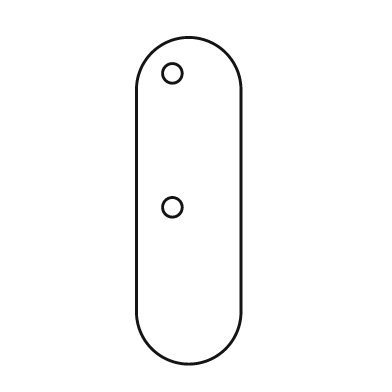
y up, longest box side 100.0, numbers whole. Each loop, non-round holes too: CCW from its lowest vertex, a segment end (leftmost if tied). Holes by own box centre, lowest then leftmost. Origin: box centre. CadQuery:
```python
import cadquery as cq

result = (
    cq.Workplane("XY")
    .moveTo(-16.0, -34.0)
    .threePointArc((0.0, -50.0), (16.0, -34.0))
    .lineTo(16.0, 34.0)
    .threePointArc((0.0, 50.0), (-16.0, 34.0))
    .close()
    .moveTo(-5.0, -2.0)
    .circle(3.0)
    .moveTo(-5.0, 39.0)
    .circle(3.0)
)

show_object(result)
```